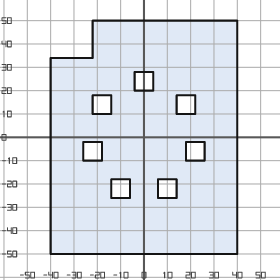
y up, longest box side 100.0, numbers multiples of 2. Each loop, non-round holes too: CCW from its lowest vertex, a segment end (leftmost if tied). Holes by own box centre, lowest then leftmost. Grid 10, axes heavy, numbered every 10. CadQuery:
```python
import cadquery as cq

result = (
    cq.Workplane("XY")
    .moveTo(-40.0, -50.0)
    .lineTo(40.0, -50.0)
    .lineTo(40.0, 50.0)
    .lineTo(-22.0, 50.0)
    .lineTo(-22.0, 34.0)
    .lineTo(-40.0, 34.0)
    .close()
    .moveTo(-14.0, -26.0)
    .lineTo(-6.0, -26.0)
    .lineTo(-6.0, -18.0)
    .lineTo(-14.0, -18.0)
    .close()
    .moveTo(6.0, -26.0)
    .lineTo(14.0, -26.0)
    .lineTo(14.0, -18.0)
    .lineTo(6.0, -18.0)
    .close()
    .moveTo(-26.0, -10.0)
    .lineTo(-18.0, -10.0)
    .lineTo(-18.0, -2.0)
    .lineTo(-26.0, -2.0)
    .close()
    .moveTo(18.0, -10.0)
    .lineTo(26.0, -10.0)
    .lineTo(26.0, -2.0)
    .lineTo(18.0, -2.0)
    .close()
    .moveTo(-22.0, 10.0)
    .lineTo(-14.0, 10.0)
    .lineTo(-14.0, 18.0)
    .lineTo(-22.0, 18.0)
    .close()
    .moveTo(14.0, 10.0)
    .lineTo(22.0, 10.0)
    .lineTo(22.0, 18.0)
    .lineTo(14.0, 18.0)
    .close()
    .moveTo(-4.0, 20.0)
    .lineTo(4.0, 20.0)
    .lineTo(4.0, 28.0)
    .lineTo(-4.0, 28.0)
    .close()
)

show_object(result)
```